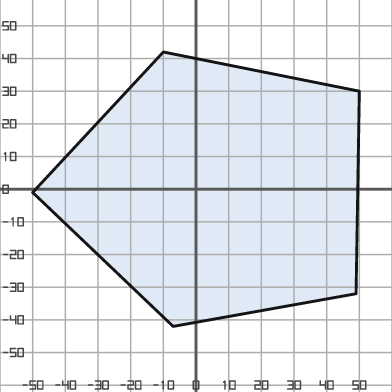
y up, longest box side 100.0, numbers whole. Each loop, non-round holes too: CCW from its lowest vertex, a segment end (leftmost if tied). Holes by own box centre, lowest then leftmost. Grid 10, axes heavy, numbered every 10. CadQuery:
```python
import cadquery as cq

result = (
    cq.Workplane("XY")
    .moveTo(-7.0, -42.0)
    .lineTo(49.0, -32.0)
    .lineTo(50.0, 30.0)
    .lineTo(-10.0, 42.0)
    .lineTo(-50.0, -1.0)
    .close()
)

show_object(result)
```